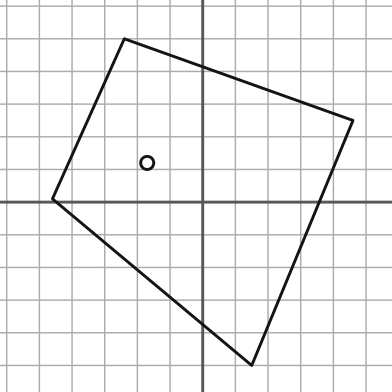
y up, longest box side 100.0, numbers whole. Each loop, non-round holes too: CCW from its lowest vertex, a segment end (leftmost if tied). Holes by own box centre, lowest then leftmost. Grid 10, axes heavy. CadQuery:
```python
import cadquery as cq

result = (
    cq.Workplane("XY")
    .moveTo(15.0, -50.0)
    .lineTo(46.0, 25.0)
    .lineTo(-24.0, 50.0)
    .lineTo(-46.0, 1.0)
    .close()
    .moveTo(-17.0, 12.0)
    .circle(2.0)
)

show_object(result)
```